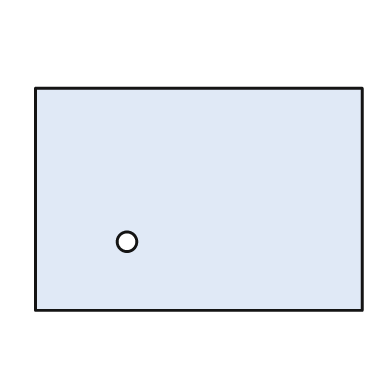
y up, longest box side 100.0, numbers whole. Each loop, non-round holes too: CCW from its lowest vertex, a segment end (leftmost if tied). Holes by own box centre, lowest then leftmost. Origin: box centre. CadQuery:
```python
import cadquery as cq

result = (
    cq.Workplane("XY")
    .moveTo(-50.0, -34.0)
    .lineTo(50.0, -34.0)
    .lineTo(50.0, 34.0)
    .lineTo(-50.0, 34.0)
    .close()
    .moveTo(-22.0, -13.0)
    .circle(3.0)
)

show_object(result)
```